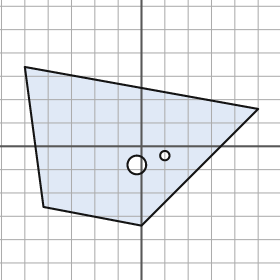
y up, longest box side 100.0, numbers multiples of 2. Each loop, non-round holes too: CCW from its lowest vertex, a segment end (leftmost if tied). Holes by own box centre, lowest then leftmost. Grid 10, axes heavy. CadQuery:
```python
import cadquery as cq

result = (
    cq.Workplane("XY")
    .moveTo(0.0, -34.0)
    .lineTo(50.0, 16.0)
    .lineTo(-50.0, 34.0)
    .lineTo(-42.0, -26.0)
    .close()
    .moveTo(-2.0, -8.0)
    .circle(4.0)
    .moveTo(10.0, -4.0)
    .circle(2.0)
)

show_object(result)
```